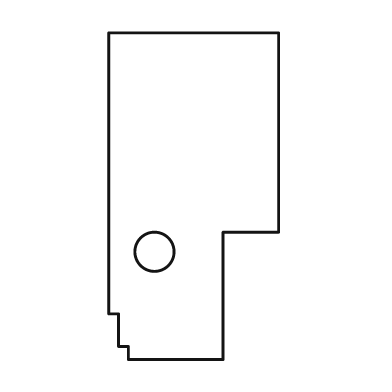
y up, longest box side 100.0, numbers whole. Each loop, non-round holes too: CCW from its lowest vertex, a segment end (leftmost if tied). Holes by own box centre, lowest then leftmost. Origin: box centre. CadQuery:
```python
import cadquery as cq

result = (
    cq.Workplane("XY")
    .moveTo(-20.0, -50.0)
    .lineTo(9.0, -50.0)
    .lineTo(9.0, -11.0)
    .lineTo(26.0, -11.0)
    .lineTo(26.0, 50.0)
    .lineTo(-26.0, 50.0)
    .lineTo(-26.0, -36.0)
    .lineTo(-23.0, -36.0)
    .lineTo(-23.0, -46.0)
    .lineTo(-20.0, -46.0)
    .close()
    .moveTo(-12.0, -17.0)
    .circle(6.0)
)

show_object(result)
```